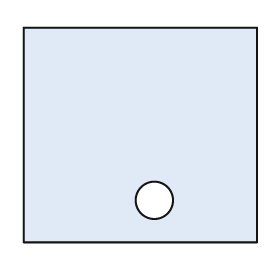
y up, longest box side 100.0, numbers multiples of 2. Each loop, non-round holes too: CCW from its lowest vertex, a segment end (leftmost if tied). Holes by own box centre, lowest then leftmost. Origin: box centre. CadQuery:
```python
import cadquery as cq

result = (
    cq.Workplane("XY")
    .moveTo(-50.0, -46.0)
    .lineTo(50.0, -46.0)
    .lineTo(50.0, 46.0)
    .lineTo(-50.0, 46.0)
    .close()
    .moveTo(6.0, -28.0)
    .circle(8.0)
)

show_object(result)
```